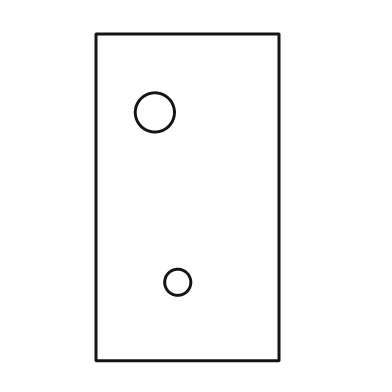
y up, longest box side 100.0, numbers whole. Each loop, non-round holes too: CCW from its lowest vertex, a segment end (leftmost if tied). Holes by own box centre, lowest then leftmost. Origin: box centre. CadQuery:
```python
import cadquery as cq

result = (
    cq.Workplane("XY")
    .moveTo(-28.0, -50.0)
    .lineTo(28.0, -50.0)
    .lineTo(28.0, 50.0)
    .lineTo(-28.0, 50.0)
    .close()
    .moveTo(-3.0, -26.0)
    .circle(4.0)
    .moveTo(-10.0, 26.0)
    .circle(6.0)
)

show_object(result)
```